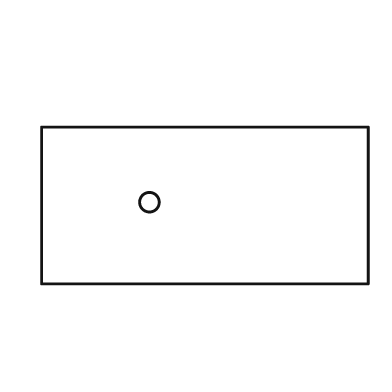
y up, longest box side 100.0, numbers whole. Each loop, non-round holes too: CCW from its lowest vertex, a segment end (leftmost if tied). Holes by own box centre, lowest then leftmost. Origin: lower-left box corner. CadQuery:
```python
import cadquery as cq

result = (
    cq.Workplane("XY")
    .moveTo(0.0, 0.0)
    .lineTo(100.0, 0.0)
    .lineTo(100.0, 48.0)
    .lineTo(0.0, 48.0)
    .close()
    .moveTo(33.0, 25.0)
    .circle(3.0)
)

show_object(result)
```